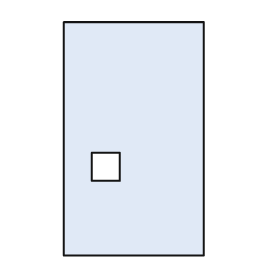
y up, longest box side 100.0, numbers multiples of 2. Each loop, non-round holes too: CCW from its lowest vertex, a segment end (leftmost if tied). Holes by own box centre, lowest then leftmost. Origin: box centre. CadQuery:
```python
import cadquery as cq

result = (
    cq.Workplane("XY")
    .moveTo(-30.0, -50.0)
    .lineTo(30.0, -50.0)
    .lineTo(30.0, 50.0)
    .lineTo(-30.0, 50.0)
    .close()
    .moveTo(-18.0, -18.0)
    .lineTo(-6.0, -18.0)
    .lineTo(-6.0, -6.0)
    .lineTo(-18.0, -6.0)
    .close()
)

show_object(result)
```